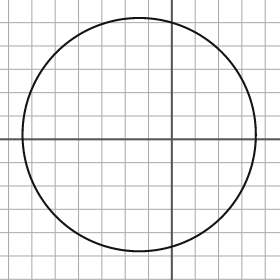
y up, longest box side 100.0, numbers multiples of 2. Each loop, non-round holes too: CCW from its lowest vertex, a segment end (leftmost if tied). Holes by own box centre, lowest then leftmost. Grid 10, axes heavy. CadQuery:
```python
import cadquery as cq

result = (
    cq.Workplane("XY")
    .moveTo(-14.0, 2.0)
    .circle(50.0)
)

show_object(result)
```